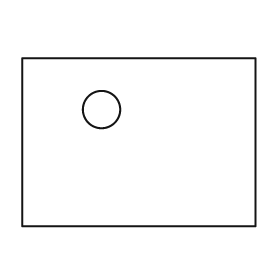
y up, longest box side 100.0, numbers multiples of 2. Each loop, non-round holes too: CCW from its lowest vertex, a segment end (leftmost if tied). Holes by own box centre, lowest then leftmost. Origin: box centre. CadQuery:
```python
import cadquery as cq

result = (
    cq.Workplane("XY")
    .moveTo(-50.0, -36.0)
    .lineTo(50.0, -36.0)
    .lineTo(50.0, 36.0)
    .lineTo(-50.0, 36.0)
    .close()
    .moveTo(-16.0, 14.0)
    .circle(8.0)
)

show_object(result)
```